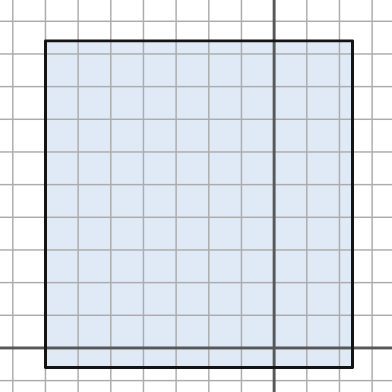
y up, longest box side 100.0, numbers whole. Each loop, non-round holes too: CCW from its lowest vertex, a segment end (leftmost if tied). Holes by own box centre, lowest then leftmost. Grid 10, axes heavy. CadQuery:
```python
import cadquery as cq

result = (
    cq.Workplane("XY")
    .moveTo(-70.0, -6.0)
    .lineTo(24.0, -6.0)
    .lineTo(24.0, 94.0)
    .lineTo(-70.0, 94.0)
    .close()
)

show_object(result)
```